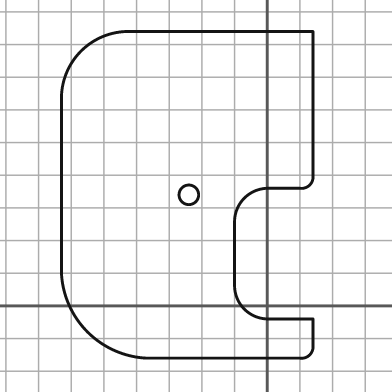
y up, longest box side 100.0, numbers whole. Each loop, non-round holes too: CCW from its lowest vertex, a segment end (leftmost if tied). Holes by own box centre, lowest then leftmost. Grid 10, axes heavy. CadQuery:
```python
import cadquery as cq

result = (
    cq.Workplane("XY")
    .moveTo(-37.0, -16.0)
    .lineTo(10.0, -16.0)
    .threePointArc((13.0, -15.0), (14.0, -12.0))
    .lineTo(14.0, -4.0)
    .lineTo(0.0, -4.0)
    .threePointArc((-7.0, -1.0), (-10.0, 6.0))
    .lineTo(-10.0, 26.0)
    .threePointArc((-7.0, 33.0), (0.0, 36.0))
    .lineTo(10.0, 36.0)
    .threePointArc((13.0, 37.0), (14.0, 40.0))
    .lineTo(14.0, 84.0)
    .lineTo(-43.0, 84.0)
    .threePointArc((-57.0, 78.0), (-63.0, 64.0))
    .lineTo(-63.0, 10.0)
    .threePointArc((-55.0, -8.0), (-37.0, -16.0))
    .close()
    .moveTo(-24.0, 34.0)
    .circle(3.0)
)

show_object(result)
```